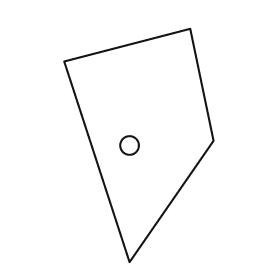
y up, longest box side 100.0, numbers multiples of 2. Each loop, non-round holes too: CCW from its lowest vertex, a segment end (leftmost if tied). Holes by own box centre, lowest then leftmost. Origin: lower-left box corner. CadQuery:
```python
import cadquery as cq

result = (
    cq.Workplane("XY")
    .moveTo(28.0, 0.0)
    .lineTo(64.0, 52.0)
    .lineTo(54.0, 100.0)
    .lineTo(0.0, 86.0)
    .close()
    .moveTo(28.0, 50.0)
    .circle(4.0)
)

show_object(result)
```